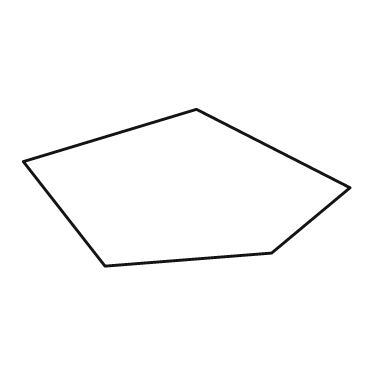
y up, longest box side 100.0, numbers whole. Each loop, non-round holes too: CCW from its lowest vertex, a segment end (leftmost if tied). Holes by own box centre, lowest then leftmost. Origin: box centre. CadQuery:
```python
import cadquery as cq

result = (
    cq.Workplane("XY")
    .moveTo(-25.0, -24.0)
    .lineTo(26.0, -20.0)
    .lineTo(50.0, 0.0)
    .lineTo(3.0, 24.0)
    .lineTo(-50.0, 8.0)
    .close()
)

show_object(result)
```